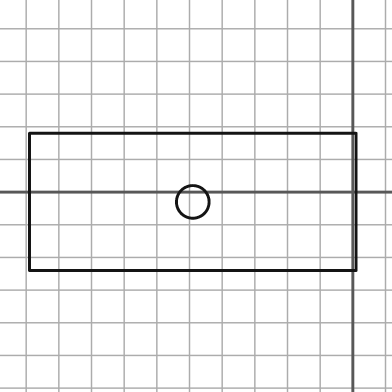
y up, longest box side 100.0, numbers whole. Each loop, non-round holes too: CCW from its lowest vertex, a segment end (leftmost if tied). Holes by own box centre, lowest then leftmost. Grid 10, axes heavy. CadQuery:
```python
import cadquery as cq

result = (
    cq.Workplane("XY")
    .moveTo(-99.0, -24.0)
    .lineTo(1.0, -24.0)
    .lineTo(1.0, 18.0)
    .lineTo(-99.0, 18.0)
    .close()
    .moveTo(-49.0, -3.0)
    .circle(5.0)
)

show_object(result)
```